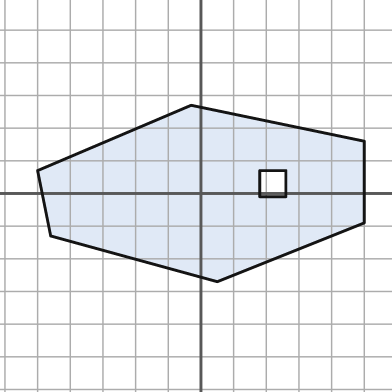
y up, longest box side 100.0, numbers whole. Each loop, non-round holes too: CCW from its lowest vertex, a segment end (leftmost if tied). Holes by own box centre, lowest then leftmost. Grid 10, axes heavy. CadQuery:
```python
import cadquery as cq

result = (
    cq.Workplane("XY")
    .moveTo(5.0, -27.0)
    .lineTo(50.0, -9.0)
    .lineTo(50.0, 16.0)
    .lineTo(-3.0, 27.0)
    .lineTo(-50.0, 7.0)
    .lineTo(-46.0, -13.0)
    .close()
    .moveTo(18.0, -1.0)
    .lineTo(26.0, -1.0)
    .lineTo(26.0, 7.0)
    .lineTo(18.0, 7.0)
    .close()
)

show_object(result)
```